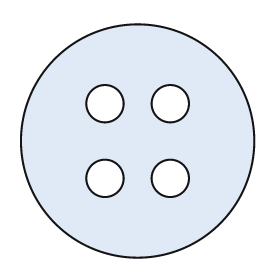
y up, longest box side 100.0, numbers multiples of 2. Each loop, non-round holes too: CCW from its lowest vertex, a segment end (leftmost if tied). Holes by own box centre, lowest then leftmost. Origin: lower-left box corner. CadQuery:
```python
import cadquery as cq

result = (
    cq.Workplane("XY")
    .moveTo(50.0, 50.0)
    .circle(50.0)
    .moveTo(36.0, 34.0)
    .circle(8.0)
    .moveTo(64.0, 34.0)
    .circle(8.0)
    .moveTo(36.0, 66.0)
    .circle(8.0)
    .moveTo(64.0, 66.0)
    .circle(8.0)
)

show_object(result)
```